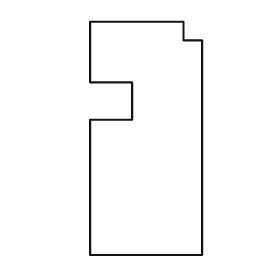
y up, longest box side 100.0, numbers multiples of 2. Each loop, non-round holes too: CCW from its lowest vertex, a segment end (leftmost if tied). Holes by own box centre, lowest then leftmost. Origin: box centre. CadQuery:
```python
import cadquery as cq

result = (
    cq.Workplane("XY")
    .moveTo(-24.0, -50.0)
    .lineTo(24.0, -50.0)
    .lineTo(24.0, 42.0)
    .lineTo(16.0, 42.0)
    .lineTo(16.0, 50.0)
    .lineTo(-24.0, 50.0)
    .lineTo(-24.0, 24.0)
    .lineTo(-6.0, 24.0)
    .lineTo(-6.0, 8.0)
    .lineTo(-24.0, 8.0)
    .close()
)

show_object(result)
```